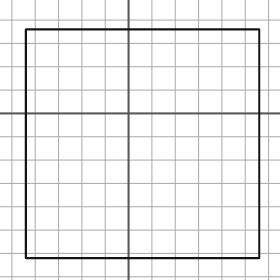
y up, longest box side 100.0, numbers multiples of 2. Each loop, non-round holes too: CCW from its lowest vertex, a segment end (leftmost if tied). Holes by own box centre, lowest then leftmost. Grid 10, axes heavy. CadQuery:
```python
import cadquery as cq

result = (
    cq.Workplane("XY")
    .moveTo(-44.0, -62.0)
    .lineTo(56.0, -62.0)
    .lineTo(56.0, 36.0)
    .lineTo(-44.0, 36.0)
    .close()
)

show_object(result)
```